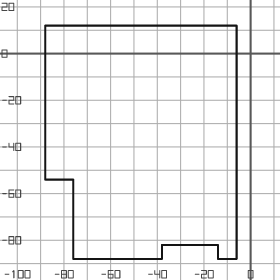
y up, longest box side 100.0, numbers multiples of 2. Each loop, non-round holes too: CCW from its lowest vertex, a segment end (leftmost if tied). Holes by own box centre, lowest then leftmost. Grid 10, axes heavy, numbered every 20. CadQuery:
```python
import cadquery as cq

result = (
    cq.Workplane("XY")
    .moveTo(-76.0, -88.0)
    .lineTo(-38.0, -88.0)
    .lineTo(-38.0, -82.0)
    .lineTo(-14.0, -82.0)
    .lineTo(-14.0, -88.0)
    .lineTo(-6.0, -88.0)
    .lineTo(-6.0, 12.0)
    .lineTo(-88.0, 12.0)
    .lineTo(-88.0, -54.0)
    .lineTo(-76.0, -54.0)
    .close()
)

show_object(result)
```